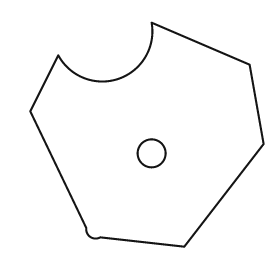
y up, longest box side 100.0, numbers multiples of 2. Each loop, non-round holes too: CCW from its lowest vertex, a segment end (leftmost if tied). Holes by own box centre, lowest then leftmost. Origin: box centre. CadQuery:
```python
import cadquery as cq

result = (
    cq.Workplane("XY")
    .moveTo(16.0, -48.0)
    .lineTo(50.0, -4.0)
    .lineTo(44.0, 30.0)
    .lineTo(2.0, 48.0)
    .threePointArc((-12.0, 24.0), (-38.0, 34.0))
    .lineTo(-50.0, 10.0)
    .lineTo(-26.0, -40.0)
    .threePointArc((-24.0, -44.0), (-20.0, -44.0))
    .close()
    .moveTo(2.0, -8.0)
    .circle(6.0)
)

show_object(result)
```